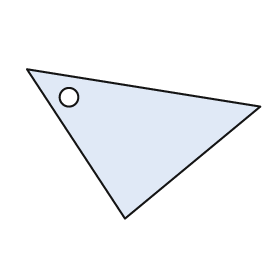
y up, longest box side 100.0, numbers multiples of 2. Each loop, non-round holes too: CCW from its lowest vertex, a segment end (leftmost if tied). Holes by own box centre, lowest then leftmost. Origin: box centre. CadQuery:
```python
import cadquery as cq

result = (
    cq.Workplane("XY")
    .moveTo(-8.0, -32.0)
    .lineTo(50.0, 16.0)
    .lineTo(-50.0, 32.0)
    .close()
    .moveTo(-32.0, 20.0)
    .circle(4.0)
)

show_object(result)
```